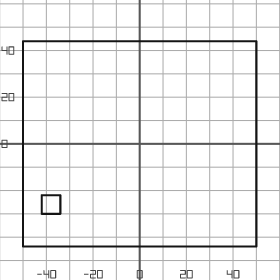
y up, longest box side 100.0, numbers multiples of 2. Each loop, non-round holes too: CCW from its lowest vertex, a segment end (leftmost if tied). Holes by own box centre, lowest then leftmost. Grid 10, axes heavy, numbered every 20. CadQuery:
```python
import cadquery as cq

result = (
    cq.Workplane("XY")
    .moveTo(-50.0, -44.0)
    .lineTo(50.0, -44.0)
    .lineTo(50.0, 44.0)
    .lineTo(-50.0, 44.0)
    .close()
    .moveTo(-42.0, -30.0)
    .lineTo(-34.0, -30.0)
    .lineTo(-34.0, -22.0)
    .lineTo(-42.0, -22.0)
    .close()
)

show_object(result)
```